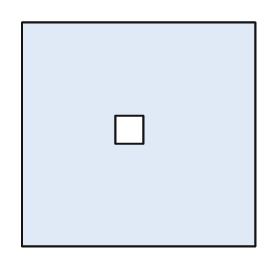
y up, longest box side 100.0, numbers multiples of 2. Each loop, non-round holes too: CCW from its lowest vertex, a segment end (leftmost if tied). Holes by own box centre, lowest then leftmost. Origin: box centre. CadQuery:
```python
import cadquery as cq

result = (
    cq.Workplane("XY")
    .moveTo(-50.0, -48.0)
    .lineTo(50.0, -48.0)
    .lineTo(50.0, 48.0)
    .lineTo(-50.0, 48.0)
    .close()
    .moveTo(-10.0, -4.0)
    .lineTo(2.0, -4.0)
    .lineTo(2.0, 8.0)
    .lineTo(-10.0, 8.0)
    .close()
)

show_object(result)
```